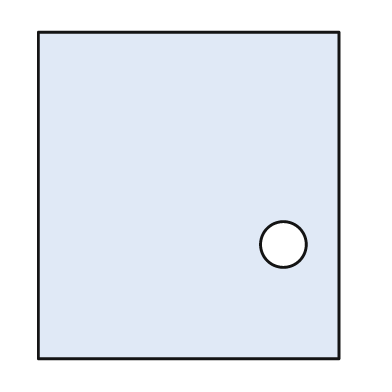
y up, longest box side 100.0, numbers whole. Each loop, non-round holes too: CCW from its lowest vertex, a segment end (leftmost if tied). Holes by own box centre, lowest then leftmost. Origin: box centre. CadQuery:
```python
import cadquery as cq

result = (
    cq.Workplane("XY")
    .moveTo(-46.0, -50.0)
    .lineTo(46.0, -50.0)
    .lineTo(46.0, 50.0)
    .lineTo(-46.0, 50.0)
    .close()
    .moveTo(29.0, -15.0)
    .circle(7.0)
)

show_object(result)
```